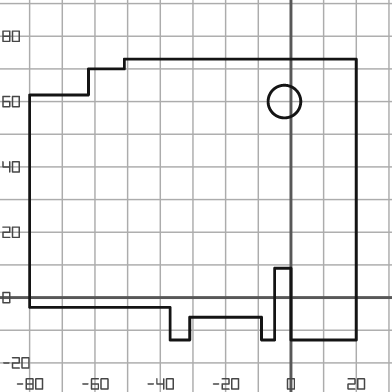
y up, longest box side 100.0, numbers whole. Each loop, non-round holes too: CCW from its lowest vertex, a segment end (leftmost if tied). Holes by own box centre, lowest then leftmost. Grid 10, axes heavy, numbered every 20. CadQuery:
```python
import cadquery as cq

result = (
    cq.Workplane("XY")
    .moveTo(-37.0, -13.0)
    .lineTo(-31.0, -13.0)
    .lineTo(-31.0, -6.0)
    .lineTo(-9.0, -6.0)
    .lineTo(-9.0, -13.0)
    .lineTo(-5.0, -13.0)
    .lineTo(-5.0, 9.0)
    .lineTo(0.0, 9.0)
    .lineTo(0.0, -13.0)
    .lineTo(20.0, -13.0)
    .lineTo(20.0, 73.0)
    .lineTo(-51.0, 73.0)
    .lineTo(-51.0, 70.0)
    .lineTo(-62.0, 70.0)
    .lineTo(-62.0, 62.0)
    .lineTo(-80.0, 62.0)
    .lineTo(-80.0, -3.0)
    .lineTo(-37.0, -3.0)
    .close()
    .moveTo(-2.0, 60.0)
    .circle(5.0)
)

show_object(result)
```